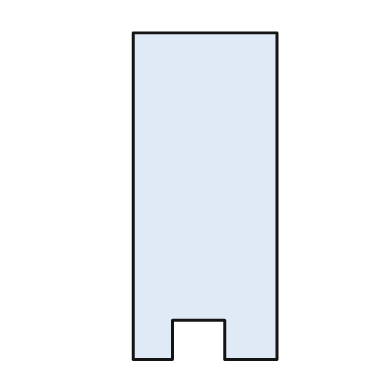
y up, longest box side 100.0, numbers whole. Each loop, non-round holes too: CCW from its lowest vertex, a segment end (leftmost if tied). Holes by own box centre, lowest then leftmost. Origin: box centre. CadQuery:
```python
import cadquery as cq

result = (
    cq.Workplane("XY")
    .moveTo(-22.0, -50.0)
    .lineTo(-10.0, -50.0)
    .lineTo(-10.0, -38.0)
    .lineTo(6.0, -38.0)
    .lineTo(6.0, -50.0)
    .lineTo(22.0, -50.0)
    .lineTo(22.0, 50.0)
    .lineTo(-22.0, 50.0)
    .close()
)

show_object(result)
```